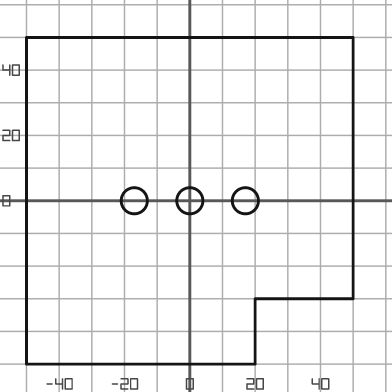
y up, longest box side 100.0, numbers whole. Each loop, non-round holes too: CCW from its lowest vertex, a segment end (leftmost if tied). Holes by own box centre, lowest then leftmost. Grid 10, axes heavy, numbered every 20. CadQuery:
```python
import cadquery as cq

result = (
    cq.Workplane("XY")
    .moveTo(-50.0, -50.0)
    .lineTo(20.0, -50.0)
    .lineTo(20.0, -30.0)
    .lineTo(50.0, -30.0)
    .lineTo(50.0, 50.0)
    .lineTo(-50.0, 50.0)
    .close()
    .moveTo(-17.0, 0.0)
    .circle(4.0)
    .moveTo(0.0, 0.0)
    .circle(4.0)
    .moveTo(17.0, 0.0)
    .circle(4.0)
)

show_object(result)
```